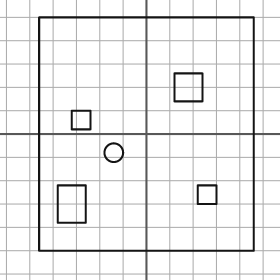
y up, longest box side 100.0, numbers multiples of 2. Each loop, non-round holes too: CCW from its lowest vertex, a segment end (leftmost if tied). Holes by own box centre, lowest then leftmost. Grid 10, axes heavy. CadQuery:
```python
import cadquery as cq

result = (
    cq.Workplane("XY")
    .moveTo(-46.0, -50.0)
    .lineTo(46.0, -50.0)
    .lineTo(46.0, 50.0)
    .lineTo(-46.0, 50.0)
    .close()
    .moveTo(-38.0, -38.0)
    .lineTo(-26.0, -38.0)
    .lineTo(-26.0, -22.0)
    .lineTo(-38.0, -22.0)
    .close()
    .moveTo(22.0, -30.0)
    .lineTo(30.0, -30.0)
    .lineTo(30.0, -22.0)
    .lineTo(22.0, -22.0)
    .close()
    .moveTo(-14.0, -8.0)
    .circle(4.0)
    .moveTo(-32.0, 2.0)
    .lineTo(-24.0, 2.0)
    .lineTo(-24.0, 10.0)
    .lineTo(-32.0, 10.0)
    .close()
    .moveTo(12.0, 14.0)
    .lineTo(24.0, 14.0)
    .lineTo(24.0, 26.0)
    .lineTo(12.0, 26.0)
    .close()
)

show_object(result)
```